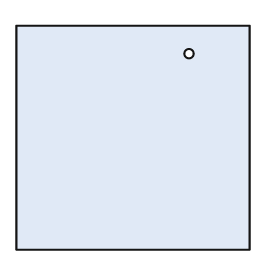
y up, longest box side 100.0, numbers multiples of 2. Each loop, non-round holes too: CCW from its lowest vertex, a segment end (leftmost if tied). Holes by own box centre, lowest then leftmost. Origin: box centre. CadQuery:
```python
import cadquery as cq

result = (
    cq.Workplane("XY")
    .moveTo(-50.0, -48.0)
    .lineTo(50.0, -48.0)
    .lineTo(50.0, 48.0)
    .lineTo(-50.0, 48.0)
    .close()
    .moveTo(24.0, 36.0)
    .circle(2.0)
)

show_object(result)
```